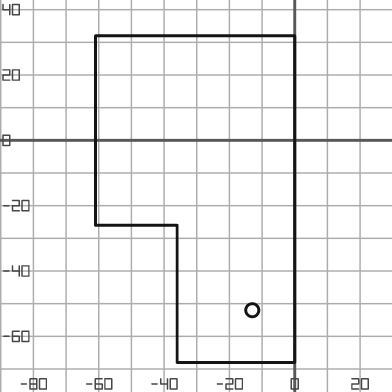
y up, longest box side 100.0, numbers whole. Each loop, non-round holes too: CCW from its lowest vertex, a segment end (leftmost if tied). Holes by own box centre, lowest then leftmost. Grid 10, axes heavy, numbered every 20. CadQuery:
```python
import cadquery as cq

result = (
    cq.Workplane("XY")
    .moveTo(-36.0, -68.0)
    .lineTo(0.0, -68.0)
    .lineTo(0.0, 32.0)
    .lineTo(-61.0, 32.0)
    .lineTo(-61.0, -26.0)
    .lineTo(-36.0, -26.0)
    .close()
    .moveTo(-13.0, -52.0)
    .circle(2.0)
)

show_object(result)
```